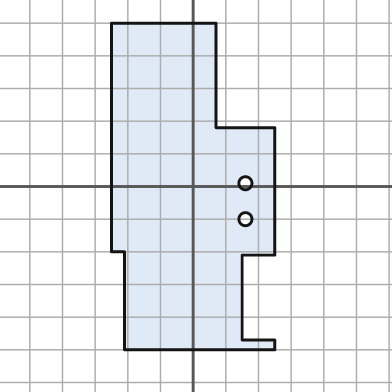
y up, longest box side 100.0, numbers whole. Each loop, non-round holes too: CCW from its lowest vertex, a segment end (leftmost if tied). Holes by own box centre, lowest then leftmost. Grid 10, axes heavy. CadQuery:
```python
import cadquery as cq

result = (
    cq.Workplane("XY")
    .moveTo(-21.0, -50.0)
    .lineTo(25.0, -50.0)
    .lineTo(25.0, -47.0)
    .lineTo(15.0, -47.0)
    .lineTo(15.0, -21.0)
    .lineTo(25.0, -21.0)
    .lineTo(25.0, 18.0)
    .lineTo(7.0, 18.0)
    .lineTo(7.0, 50.0)
    .lineTo(-25.0, 50.0)
    .lineTo(-25.0, -20.0)
    .lineTo(-21.0, -20.0)
    .close()
    .moveTo(16.0, -10.0)
    .circle(2.0)
    .moveTo(16.0, 1.0)
    .circle(2.0)
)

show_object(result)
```